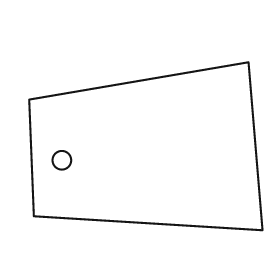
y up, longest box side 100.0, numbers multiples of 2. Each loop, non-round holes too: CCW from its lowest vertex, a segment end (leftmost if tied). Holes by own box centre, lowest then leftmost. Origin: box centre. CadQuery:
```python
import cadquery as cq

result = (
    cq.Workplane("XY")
    .moveTo(50.0, -36.0)
    .lineTo(44.0, 36.0)
    .lineTo(-50.0, 20.0)
    .lineTo(-48.0, -30.0)
    .close()
    .moveTo(-36.0, -6.0)
    .circle(4.0)
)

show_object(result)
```